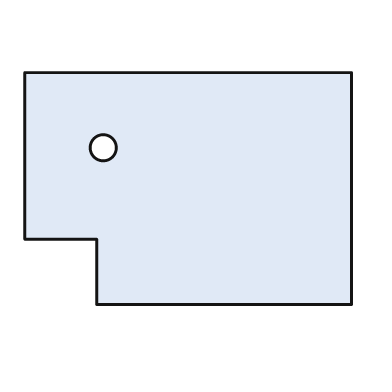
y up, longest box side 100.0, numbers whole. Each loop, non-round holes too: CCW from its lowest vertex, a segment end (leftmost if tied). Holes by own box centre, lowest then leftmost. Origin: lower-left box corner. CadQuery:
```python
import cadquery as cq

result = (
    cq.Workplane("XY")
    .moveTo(22.0, 0.0)
    .lineTo(100.0, 0.0)
    .lineTo(100.0, 71.0)
    .lineTo(0.0, 71.0)
    .lineTo(0.0, 20.0)
    .lineTo(22.0, 20.0)
    .close()
    .moveTo(24.0, 48.0)
    .circle(4.0)
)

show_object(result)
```